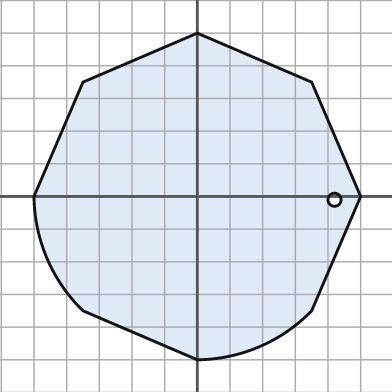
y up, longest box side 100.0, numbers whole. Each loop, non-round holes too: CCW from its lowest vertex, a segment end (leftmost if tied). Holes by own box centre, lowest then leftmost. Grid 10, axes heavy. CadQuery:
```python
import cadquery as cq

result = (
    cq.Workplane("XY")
    .moveTo(0.0, -50.0)
    .threePointArc((19.0, -46.0), (35.0, -35.0))
    .lineTo(50.0, 0.0)
    .lineTo(35.0, 35.0)
    .lineTo(0.0, 50.0)
    .lineTo(-35.0, 35.0)
    .lineTo(-50.0, 0.0)
    .threePointArc((-46.0, -19.0), (-35.0, -35.0))
    .close()
    .moveTo(42.0, -1.0)
    .circle(2.0)
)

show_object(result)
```